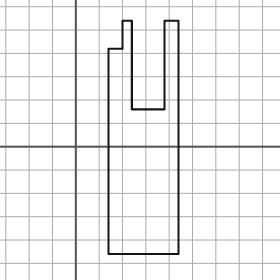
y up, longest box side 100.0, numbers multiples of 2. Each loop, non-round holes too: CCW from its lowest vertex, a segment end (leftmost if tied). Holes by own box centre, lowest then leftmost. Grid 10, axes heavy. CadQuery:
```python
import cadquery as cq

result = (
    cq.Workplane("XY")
    .moveTo(14.0, -46.0)
    .lineTo(44.0, -46.0)
    .lineTo(44.0, 54.0)
    .lineTo(38.0, 54.0)
    .lineTo(38.0, 16.0)
    .lineTo(24.0, 16.0)
    .lineTo(24.0, 54.0)
    .lineTo(20.0, 54.0)
    .lineTo(20.0, 42.0)
    .lineTo(14.0, 42.0)
    .close()
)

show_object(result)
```